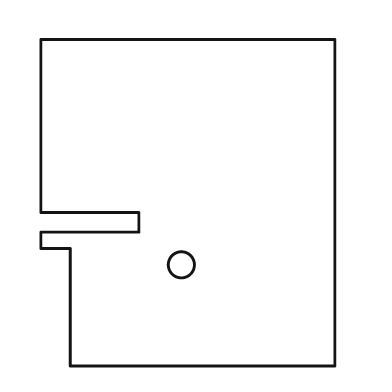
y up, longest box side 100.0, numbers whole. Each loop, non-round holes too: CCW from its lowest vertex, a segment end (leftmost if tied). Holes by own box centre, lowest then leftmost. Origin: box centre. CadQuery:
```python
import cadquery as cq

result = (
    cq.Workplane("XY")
    .moveTo(-36.0, -50.0)
    .lineTo(45.0, -50.0)
    .lineTo(45.0, 50.0)
    .lineTo(-45.0, 50.0)
    .lineTo(-45.0, -3.0)
    .lineTo(-15.0, -3.0)
    .lineTo(-15.0, -9.0)
    .lineTo(-45.0, -9.0)
    .lineTo(-45.0, -14.0)
    .lineTo(-36.0, -14.0)
    .close()
    .moveTo(-2.0, -19.0)
    .circle(4.0)
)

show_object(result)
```